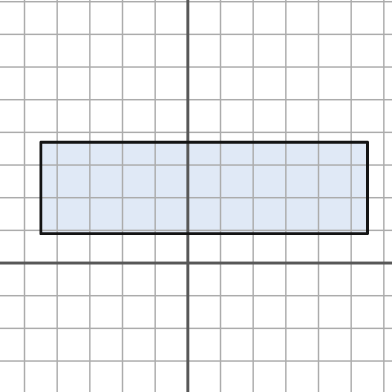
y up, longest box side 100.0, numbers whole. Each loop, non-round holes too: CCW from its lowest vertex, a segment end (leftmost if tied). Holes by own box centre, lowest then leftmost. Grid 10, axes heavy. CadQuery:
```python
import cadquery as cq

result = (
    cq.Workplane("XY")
    .moveTo(-45.0, 9.0)
    .lineTo(55.0, 9.0)
    .lineTo(55.0, 37.0)
    .lineTo(-45.0, 37.0)
    .close()
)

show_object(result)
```